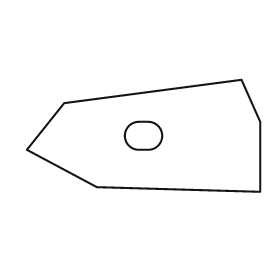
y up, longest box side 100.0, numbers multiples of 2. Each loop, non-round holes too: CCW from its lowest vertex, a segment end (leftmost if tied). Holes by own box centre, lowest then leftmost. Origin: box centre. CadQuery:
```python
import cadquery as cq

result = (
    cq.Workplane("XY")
    .moveTo(50.0, -24.0)
    .lineTo(50.0, 6.0)
    .lineTo(42.0, 24.0)
    .lineTo(-34.0, 14.0)
    .lineTo(-50.0, -6.0)
    .lineTo(-20.0, -22.0)
    .close()
    .moveTo(-2.0, -6.0)
    .lineTo(2.0, -6.0)
    .threePointArc((8.0, 0.0), (2.0, 6.0))
    .lineTo(-2.0, 6.0)
    .threePointArc((-8.0, 0.0), (-2.0, -6.0))
    .close()
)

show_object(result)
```